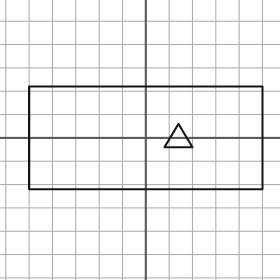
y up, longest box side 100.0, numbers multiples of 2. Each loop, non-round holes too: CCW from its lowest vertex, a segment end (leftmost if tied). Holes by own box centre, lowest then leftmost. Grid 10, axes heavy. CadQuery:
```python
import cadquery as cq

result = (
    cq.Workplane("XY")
    .moveTo(-50.0, -22.0)
    .lineTo(50.0, -22.0)
    .lineTo(50.0, 22.0)
    .lineTo(-50.0, 22.0)
    .close()
    .moveTo(8.0, -4.0)
    .lineTo(20.0, -4.0)
    .lineTo(14.0, 6.0)
    .close()
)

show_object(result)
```